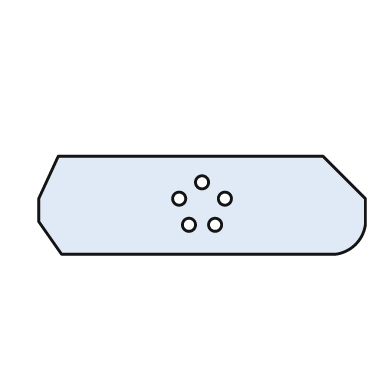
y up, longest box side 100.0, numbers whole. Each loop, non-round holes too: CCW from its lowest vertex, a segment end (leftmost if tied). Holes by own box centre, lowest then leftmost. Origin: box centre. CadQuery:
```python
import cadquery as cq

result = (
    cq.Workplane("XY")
    .moveTo(-43.0, -15.0)
    .lineTo(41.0, -15.0)
    .threePointArc((47.0, -12.0), (50.0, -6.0))
    .lineTo(50.0, 2.0)
    .lineTo(37.0, 15.0)
    .lineTo(-44.0, 15.0)
    .lineTo(-50.0, 2.0)
    .lineTo(-50.0, -5.0)
    .close()
    .moveTo(-4.0, -6.0)
    .circle(2.0)
    .moveTo(4.0, -6.0)
    .circle(2.0)
    .moveTo(-7.0, 2.0)
    .circle(2.0)
    .moveTo(7.0, 2.0)
    .circle(2.0)
    .moveTo(0.0, 7.0)
    .circle(2.0)
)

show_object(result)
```